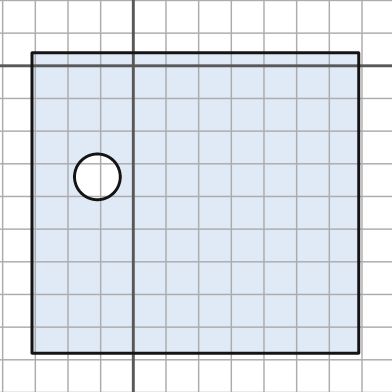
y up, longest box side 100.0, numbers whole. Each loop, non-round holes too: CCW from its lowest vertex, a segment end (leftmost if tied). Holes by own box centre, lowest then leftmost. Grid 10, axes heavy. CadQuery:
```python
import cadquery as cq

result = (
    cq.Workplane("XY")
    .moveTo(-31.0, -88.0)
    .lineTo(69.0, -88.0)
    .lineTo(69.0, 4.0)
    .lineTo(-31.0, 4.0)
    .close()
    .moveTo(-11.0, -34.0)
    .circle(7.0)
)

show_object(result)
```